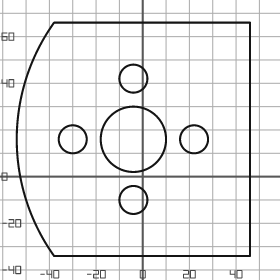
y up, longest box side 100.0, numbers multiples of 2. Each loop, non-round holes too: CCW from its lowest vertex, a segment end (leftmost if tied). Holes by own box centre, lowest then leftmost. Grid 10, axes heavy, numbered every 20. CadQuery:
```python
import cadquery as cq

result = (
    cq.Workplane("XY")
    .moveTo(-38.0, -34.0)
    .lineTo(46.0, -34.0)
    .lineTo(46.0, 66.0)
    .lineTo(-38.0, 66.0)
    .threePointArc((-54.0, 16.0), (-38.0, -34.0))
    .close()
    .moveTo(-4.0, -10.0)
    .circle(6.0)
    .moveTo(-30.0, 16.0)
    .circle(6.0)
    .moveTo(-4.0, 16.0)
    .circle(14.0)
    .moveTo(22.0, 16.0)
    .circle(6.0)
    .moveTo(-4.0, 42.0)
    .circle(6.0)
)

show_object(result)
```